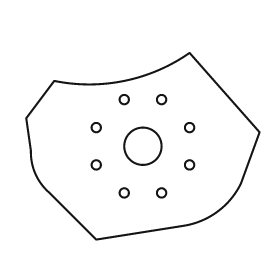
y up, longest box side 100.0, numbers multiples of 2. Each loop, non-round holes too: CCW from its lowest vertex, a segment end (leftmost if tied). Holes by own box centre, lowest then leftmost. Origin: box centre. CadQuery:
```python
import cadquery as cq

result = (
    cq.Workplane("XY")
    .moveTo(-20.0, -40.0)
    .lineTo(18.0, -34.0)
    .threePointArc((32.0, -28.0), (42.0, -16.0))
    .lineTo(50.0, 6.0)
    .lineTo(20.0, 40.0)
    .threePointArc((-8.0, 28.0), (-38.0, 28.0))
    .lineTo(-50.0, 12.0)
    .lineTo(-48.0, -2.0)
    .threePointArc((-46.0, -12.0), (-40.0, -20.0))
    .close()
    .moveTo(-8.0, -20.0)
    .circle(2.0)
    .moveTo(8.0, -20.0)
    .circle(2.0)
    .moveTo(-20.0, -8.0)
    .circle(2.0)
    .moveTo(20.0, -8.0)
    .circle(2.0)
    .moveTo(0.0, 0.0)
    .circle(8.0)
    .moveTo(-20.0, 8.0)
    .circle(2.0)
    .moveTo(20.0, 8.0)
    .circle(2.0)
    .moveTo(-8.0, 20.0)
    .circle(2.0)
    .moveTo(8.0, 20.0)
    .circle(2.0)
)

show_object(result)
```